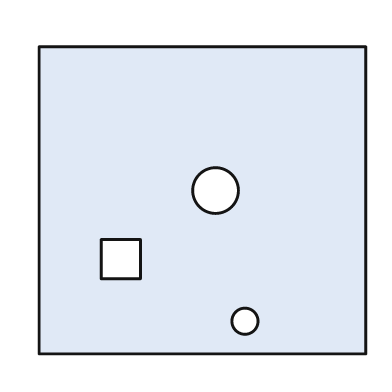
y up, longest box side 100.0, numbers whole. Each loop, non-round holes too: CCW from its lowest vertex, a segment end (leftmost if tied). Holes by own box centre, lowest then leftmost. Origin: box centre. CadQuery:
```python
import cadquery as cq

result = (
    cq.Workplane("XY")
    .moveTo(-50.0, -47.0)
    .lineTo(50.0, -47.0)
    .lineTo(50.0, 47.0)
    .lineTo(-50.0, 47.0)
    .close()
    .moveTo(13.0, -37.0)
    .circle(4.0)
    .moveTo(-31.0, -24.0)
    .lineTo(-19.0, -24.0)
    .lineTo(-19.0, -12.0)
    .lineTo(-31.0, -12.0)
    .close()
    .moveTo(4.0, 3.0)
    .circle(7.0)
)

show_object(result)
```